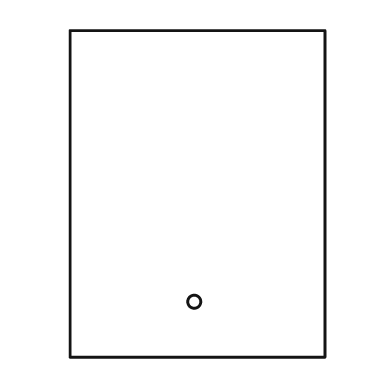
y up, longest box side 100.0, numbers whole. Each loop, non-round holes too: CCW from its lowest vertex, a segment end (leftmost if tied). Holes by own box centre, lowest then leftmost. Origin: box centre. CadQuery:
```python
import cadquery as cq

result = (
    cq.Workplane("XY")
    .moveTo(-39.0, -50.0)
    .lineTo(39.0, -50.0)
    .lineTo(39.0, 50.0)
    .lineTo(-39.0, 50.0)
    .close()
    .moveTo(-1.0, -33.0)
    .circle(2.0)
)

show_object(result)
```